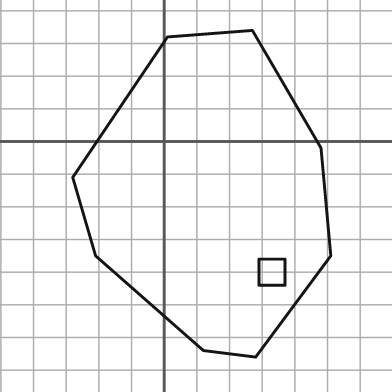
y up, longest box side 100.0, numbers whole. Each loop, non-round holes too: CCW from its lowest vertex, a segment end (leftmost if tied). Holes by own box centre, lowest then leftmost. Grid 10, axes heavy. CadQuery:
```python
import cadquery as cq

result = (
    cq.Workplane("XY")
    .moveTo(28.0, -66.0)
    .lineTo(51.0, -35.0)
    .lineTo(48.0, -2.0)
    .lineTo(27.0, 34.0)
    .lineTo(1.0, 32.0)
    .lineTo(-28.0, -11.0)
    .lineTo(-21.0, -35.0)
    .lineTo(12.0, -64.0)
    .close()
    .moveTo(29.0, -44.0)
    .lineTo(37.0, -44.0)
    .lineTo(37.0, -36.0)
    .lineTo(29.0, -36.0)
    .close()
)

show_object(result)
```